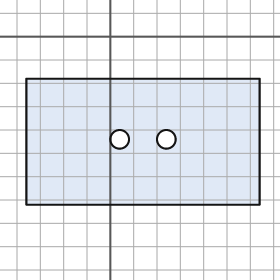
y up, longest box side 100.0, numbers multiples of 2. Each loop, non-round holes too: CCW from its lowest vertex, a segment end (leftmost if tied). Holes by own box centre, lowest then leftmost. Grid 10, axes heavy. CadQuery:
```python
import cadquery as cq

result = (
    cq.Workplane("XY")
    .moveTo(-36.0, -72.0)
    .lineTo(64.0, -72.0)
    .lineTo(64.0, -18.0)
    .lineTo(-36.0, -18.0)
    .close()
    .moveTo(4.0, -44.0)
    .circle(4.0)
    .moveTo(24.0, -44.0)
    .circle(4.0)
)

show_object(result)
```